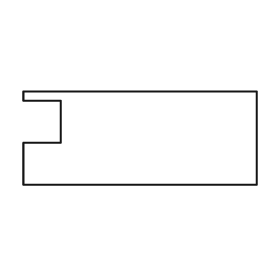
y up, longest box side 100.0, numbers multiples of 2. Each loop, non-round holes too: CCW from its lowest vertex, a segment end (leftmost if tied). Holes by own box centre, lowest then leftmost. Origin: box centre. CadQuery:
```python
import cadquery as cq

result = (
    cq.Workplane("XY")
    .moveTo(-50.0, -20.0)
    .lineTo(50.0, -20.0)
    .lineTo(50.0, 20.0)
    .lineTo(-50.0, 20.0)
    .lineTo(-50.0, 16.0)
    .lineTo(-34.0, 16.0)
    .lineTo(-34.0, -2.0)
    .lineTo(-50.0, -2.0)
    .close()
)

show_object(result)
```